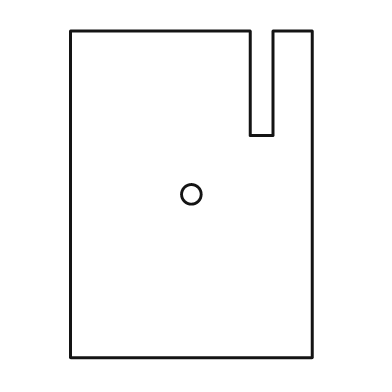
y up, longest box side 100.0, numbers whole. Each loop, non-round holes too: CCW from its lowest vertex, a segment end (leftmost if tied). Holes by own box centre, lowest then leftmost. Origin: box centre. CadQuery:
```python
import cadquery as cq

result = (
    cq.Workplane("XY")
    .moveTo(-37.0, -50.0)
    .lineTo(37.0, -50.0)
    .lineTo(37.0, 50.0)
    .lineTo(25.0, 50.0)
    .lineTo(25.0, 18.0)
    .lineTo(18.0, 18.0)
    .lineTo(18.0, 50.0)
    .lineTo(-37.0, 50.0)
    .close()
    .moveTo(0.0, 0.0)
    .circle(3.0)
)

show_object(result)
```